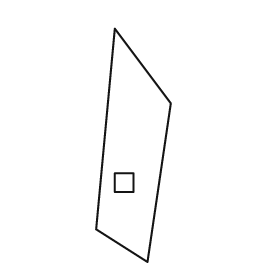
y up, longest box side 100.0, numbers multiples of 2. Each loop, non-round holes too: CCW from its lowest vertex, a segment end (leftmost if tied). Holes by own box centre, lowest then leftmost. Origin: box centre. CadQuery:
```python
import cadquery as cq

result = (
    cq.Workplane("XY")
    .moveTo(6.0, -50.0)
    .lineTo(16.0, 18.0)
    .lineTo(-8.0, 50.0)
    .lineTo(-16.0, -36.0)
    .close()
    .moveTo(-8.0, -20.0)
    .lineTo(0.0, -20.0)
    .lineTo(0.0, -12.0)
    .lineTo(-8.0, -12.0)
    .close()
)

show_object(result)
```